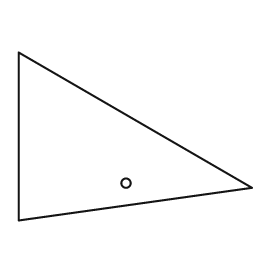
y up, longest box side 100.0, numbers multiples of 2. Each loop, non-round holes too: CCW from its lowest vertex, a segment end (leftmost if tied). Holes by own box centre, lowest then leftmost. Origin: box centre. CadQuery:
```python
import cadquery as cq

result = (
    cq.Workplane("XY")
    .moveTo(-50.0, -36.0)
    .lineTo(50.0, -22.0)
    .lineTo(-50.0, 36.0)
    .close()
    .moveTo(-4.0, -20.0)
    .circle(2.0)
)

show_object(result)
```